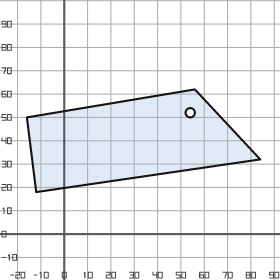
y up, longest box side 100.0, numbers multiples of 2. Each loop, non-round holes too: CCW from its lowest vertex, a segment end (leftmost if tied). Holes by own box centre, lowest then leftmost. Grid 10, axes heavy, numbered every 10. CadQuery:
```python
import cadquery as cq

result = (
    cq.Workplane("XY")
    .moveTo(-12.0, 18.0)
    .lineTo(84.0, 32.0)
    .lineTo(56.0, 62.0)
    .lineTo(-16.0, 50.0)
    .close()
    .moveTo(54.0, 52.0)
    .circle(2.0)
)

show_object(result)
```